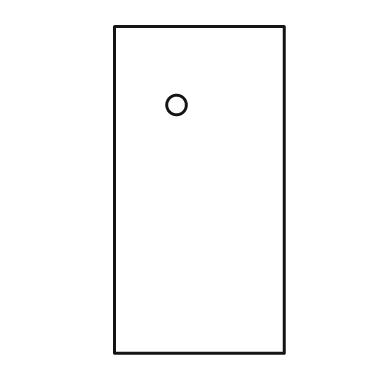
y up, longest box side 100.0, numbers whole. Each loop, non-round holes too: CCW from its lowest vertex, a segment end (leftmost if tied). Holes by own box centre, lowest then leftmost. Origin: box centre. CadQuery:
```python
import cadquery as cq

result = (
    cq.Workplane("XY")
    .moveTo(-26.0, -50.0)
    .lineTo(26.0, -50.0)
    .lineTo(26.0, 50.0)
    .lineTo(-26.0, 50.0)
    .close()
    .moveTo(-7.0, 26.0)
    .circle(3.0)
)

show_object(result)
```